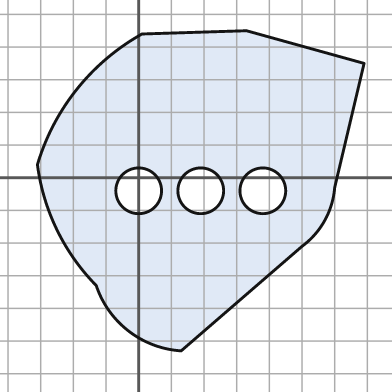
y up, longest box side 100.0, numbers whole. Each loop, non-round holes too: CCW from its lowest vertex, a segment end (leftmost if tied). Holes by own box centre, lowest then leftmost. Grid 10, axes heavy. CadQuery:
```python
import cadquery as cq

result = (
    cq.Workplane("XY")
    .moveTo(13.0, -53.0)
    .lineTo(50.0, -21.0)
    .threePointArc((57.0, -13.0), (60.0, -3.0))
    .lineTo(69.0, 35.0)
    .lineTo(33.0, 45.0)
    .lineTo(1.0, 44.0)
    .threePointArc((-19.0, 27.0), (-31.0, 4.0))
    .threePointArc((-25.0, -16.0), (-13.0, -33.0))
    .threePointArc((-3.0, -47.0), (13.0, -53.0))
    .close()
    .moveTo(0.0, -4.0)
    .circle(7.0)
    .moveTo(19.0, -4.0)
    .circle(7.0)
    .moveTo(38.0, -4.0)
    .circle(7.0)
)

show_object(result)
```